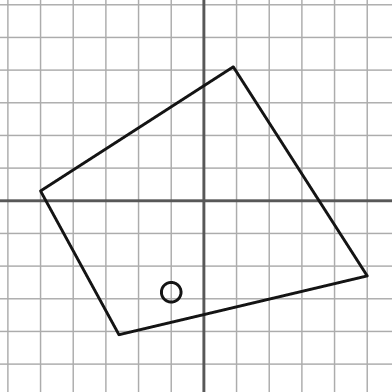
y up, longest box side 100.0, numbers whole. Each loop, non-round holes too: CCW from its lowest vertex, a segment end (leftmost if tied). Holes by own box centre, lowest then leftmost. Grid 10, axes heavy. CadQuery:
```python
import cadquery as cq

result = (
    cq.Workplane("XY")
    .moveTo(-26.0, -41.0)
    .lineTo(50.0, -23.0)
    .lineTo(9.0, 41.0)
    .lineTo(-50.0, 3.0)
    .close()
    .moveTo(-10.0, -28.0)
    .circle(3.0)
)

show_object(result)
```